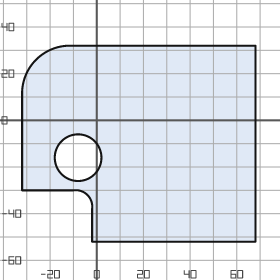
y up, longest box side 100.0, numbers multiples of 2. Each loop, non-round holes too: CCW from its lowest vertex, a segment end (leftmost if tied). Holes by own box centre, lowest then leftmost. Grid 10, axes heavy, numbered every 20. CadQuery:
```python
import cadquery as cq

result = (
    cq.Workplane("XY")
    .moveTo(-2.0, -52.0)
    .lineTo(68.0, -52.0)
    .lineTo(68.0, 32.0)
    .lineTo(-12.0, 32.0)
    .threePointArc((-26.0, 26.0), (-32.0, 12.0))
    .lineTo(-32.0, -30.0)
    .lineTo(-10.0, -30.0)
    .threePointArc((-4.0, -32.0), (-2.0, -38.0))
    .close()
    .moveTo(-8.0, -16.0)
    .circle(10.0)
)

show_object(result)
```